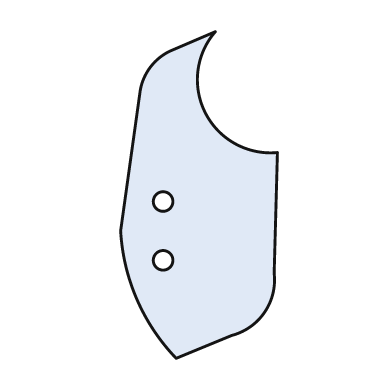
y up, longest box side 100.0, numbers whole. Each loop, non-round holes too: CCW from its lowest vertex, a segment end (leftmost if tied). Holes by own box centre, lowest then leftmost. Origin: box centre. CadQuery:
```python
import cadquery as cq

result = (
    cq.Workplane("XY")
    .moveTo(-7.0, -50.0)
    .lineTo(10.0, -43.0)
    .threePointArc((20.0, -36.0), (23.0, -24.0))
    .lineTo(24.0, 13.0)
    .threePointArc((2.0, 25.0), (5.0, 50.0))
    .lineTo(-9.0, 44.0)
    .threePointArc((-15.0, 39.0), (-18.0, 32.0))
    .lineTo(-24.0, -11.0)
    .threePointArc((-19.0, -32.0), (-7.0, -50.0))
    .close()
    .moveTo(-11.0, -20.0)
    .circle(3.0)
    .moveTo(-11.0, -2.0)
    .circle(3.0)
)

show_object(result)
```